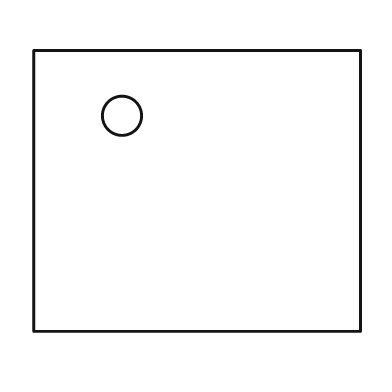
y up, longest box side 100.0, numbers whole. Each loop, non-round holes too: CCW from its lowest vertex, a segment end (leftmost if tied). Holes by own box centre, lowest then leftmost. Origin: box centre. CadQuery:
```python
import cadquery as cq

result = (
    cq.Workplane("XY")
    .moveTo(-50.0, -43.0)
    .lineTo(50.0, -43.0)
    .lineTo(50.0, 43.0)
    .lineTo(-50.0, 43.0)
    .close()
    .moveTo(-23.0, 23.0)
    .circle(6.0)
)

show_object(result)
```